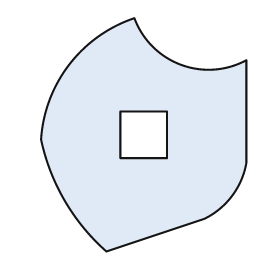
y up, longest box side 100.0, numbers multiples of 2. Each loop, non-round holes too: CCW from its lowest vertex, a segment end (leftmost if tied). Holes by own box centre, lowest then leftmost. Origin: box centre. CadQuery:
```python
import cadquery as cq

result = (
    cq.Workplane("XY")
    .moveTo(-16.0, -50.0)
    .lineTo(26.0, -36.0)
    .threePointArc((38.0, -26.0), (44.0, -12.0))
    .lineTo(44.0, 32.0)
    .threePointArc((16.0, 30.0), (-4.0, 50.0))
    .threePointArc((-32.0, 30.0), (-44.0, -2.0))
    .threePointArc((-34.0, -28.0), (-16.0, -50.0))
    .close()
    .moveTo(-10.0, -10.0)
    .lineTo(10.0, -10.0)
    .lineTo(10.0, 10.0)
    .lineTo(-10.0, 10.0)
    .close()
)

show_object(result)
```